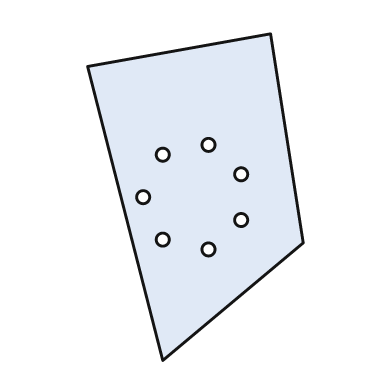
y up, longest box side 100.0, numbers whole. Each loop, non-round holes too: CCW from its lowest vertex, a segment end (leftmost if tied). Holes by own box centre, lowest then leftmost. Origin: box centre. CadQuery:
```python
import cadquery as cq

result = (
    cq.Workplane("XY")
    .moveTo(-10.0, -50.0)
    .lineTo(33.0, -14.0)
    .lineTo(23.0, 50.0)
    .lineTo(-33.0, 40.0)
    .close()
    .moveTo(4.0, -16.0)
    .circle(2.0)
    .moveTo(-10.0, -13.0)
    .circle(2.0)
    .moveTo(14.0, -7.0)
    .circle(2.0)
    .moveTo(-16.0, 0.0)
    .circle(2.0)
    .moveTo(14.0, 7.0)
    .circle(2.0)
    .moveTo(-10.0, 13.0)
    .circle(2.0)
    .moveTo(4.0, 16.0)
    .circle(2.0)
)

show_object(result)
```